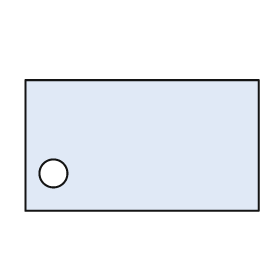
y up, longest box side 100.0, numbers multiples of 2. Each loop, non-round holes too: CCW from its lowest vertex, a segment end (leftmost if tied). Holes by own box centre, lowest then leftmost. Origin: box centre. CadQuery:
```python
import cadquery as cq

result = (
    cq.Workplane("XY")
    .moveTo(-50.0, -28.0)
    .lineTo(50.0, -28.0)
    .lineTo(50.0, 28.0)
    .lineTo(-50.0, 28.0)
    .close()
    .moveTo(-38.0, -12.0)
    .circle(6.0)
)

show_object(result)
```